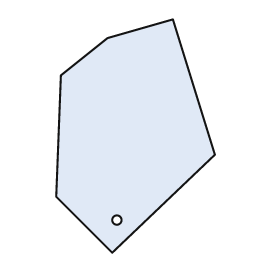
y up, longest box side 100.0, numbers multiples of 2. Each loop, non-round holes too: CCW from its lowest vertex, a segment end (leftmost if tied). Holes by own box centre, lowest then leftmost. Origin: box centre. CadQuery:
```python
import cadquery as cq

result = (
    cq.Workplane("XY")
    .moveTo(-10.0, -50.0)
    .lineTo(34.0, -8.0)
    .lineTo(16.0, 50.0)
    .lineTo(-12.0, 42.0)
    .lineTo(-32.0, 26.0)
    .lineTo(-34.0, -26.0)
    .close()
    .moveTo(-8.0, -36.0)
    .circle(2.0)
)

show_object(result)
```